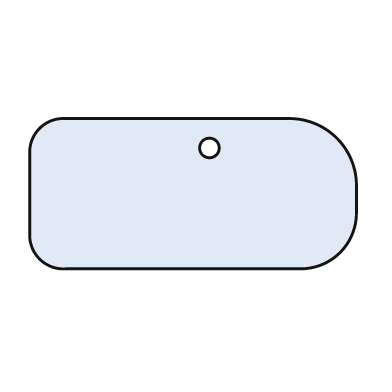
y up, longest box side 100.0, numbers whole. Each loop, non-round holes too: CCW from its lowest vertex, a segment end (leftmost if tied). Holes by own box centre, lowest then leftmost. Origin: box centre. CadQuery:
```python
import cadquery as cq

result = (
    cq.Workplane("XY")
    .moveTo(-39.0, -23.0)
    .lineTo(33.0, -23.0)
    .threePointArc((45.0, -18.0), (50.0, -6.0))
    .lineTo(50.0, 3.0)
    .threePointArc((44.0, 17.0), (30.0, 23.0))
    .lineTo(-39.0, 23.0)
    .threePointArc((-47.0, 20.0), (-50.0, 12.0))
    .lineTo(-50.0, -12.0)
    .threePointArc((-47.0, -20.0), (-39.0, -23.0))
    .close()
    .moveTo(5.0, 14.0)
    .circle(3.0)
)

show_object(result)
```